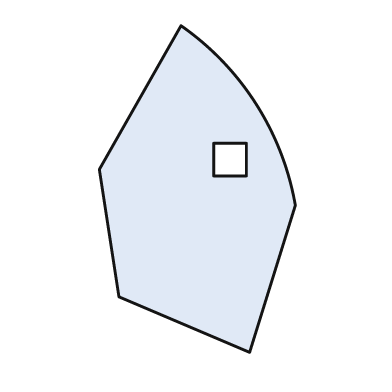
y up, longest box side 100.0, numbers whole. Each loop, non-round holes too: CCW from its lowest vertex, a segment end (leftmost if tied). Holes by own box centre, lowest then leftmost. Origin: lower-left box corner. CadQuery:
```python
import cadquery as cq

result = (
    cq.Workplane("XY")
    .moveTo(46.0, 0.0)
    .lineTo(60.0, 45.0)
    .threePointArc((48.0, 76.0), (25.0, 100.0))
    .lineTo(0.0, 56.0)
    .lineTo(6.0, 17.0)
    .close()
    .moveTo(35.0, 54.0)
    .lineTo(45.0, 54.0)
    .lineTo(45.0, 64.0)
    .lineTo(35.0, 64.0)
    .close()
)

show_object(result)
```